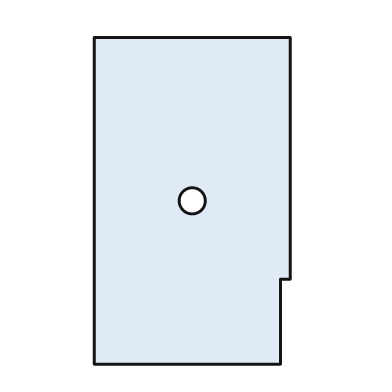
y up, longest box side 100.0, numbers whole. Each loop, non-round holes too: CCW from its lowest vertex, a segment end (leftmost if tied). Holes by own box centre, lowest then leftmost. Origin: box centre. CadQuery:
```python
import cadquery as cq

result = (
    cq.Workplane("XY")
    .moveTo(-30.0, -50.0)
    .lineTo(27.0, -50.0)
    .lineTo(27.0, -24.0)
    .lineTo(30.0, -24.0)
    .lineTo(30.0, 50.0)
    .lineTo(-30.0, 50.0)
    .close()
    .moveTo(0.0, 0.0)
    .circle(4.0)
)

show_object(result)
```